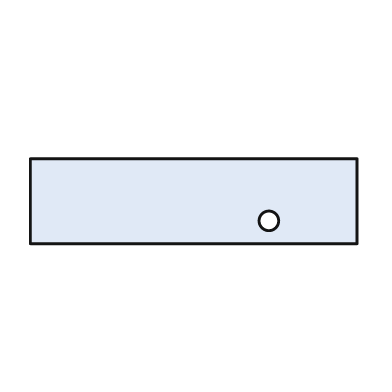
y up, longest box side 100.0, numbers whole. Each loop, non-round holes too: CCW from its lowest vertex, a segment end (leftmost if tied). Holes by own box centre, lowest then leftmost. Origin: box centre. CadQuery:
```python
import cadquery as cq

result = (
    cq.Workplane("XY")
    .moveTo(-50.0, -13.0)
    .lineTo(50.0, -13.0)
    .lineTo(50.0, 13.0)
    .lineTo(-50.0, 13.0)
    .close()
    .moveTo(23.0, -6.0)
    .circle(3.0)
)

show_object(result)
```